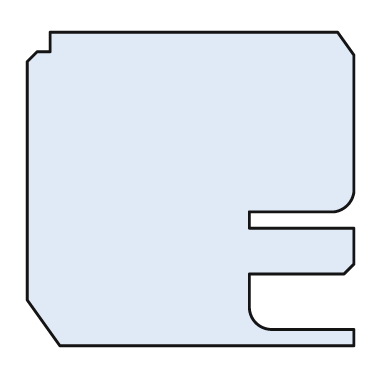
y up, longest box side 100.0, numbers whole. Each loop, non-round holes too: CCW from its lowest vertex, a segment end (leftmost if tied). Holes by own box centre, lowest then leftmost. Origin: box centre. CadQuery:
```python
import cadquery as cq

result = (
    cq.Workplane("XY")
    .moveTo(-40.0, -48.0)
    .lineTo(50.0, -48.0)
    .lineTo(50.0, -43.0)
    .lineTo(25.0, -43.0)
    .threePointArc((20.0, -41.0), (18.0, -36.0))
    .lineTo(18.0, -26.0)
    .lineTo(47.0, -26.0)
    .lineTo(50.0, -23.0)
    .lineTo(50.0, -12.0)
    .lineTo(18.0, -12.0)
    .lineTo(18.0, -7.0)
    .lineTo(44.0, -7.0)
    .threePointArc((48.0, -5.0), (50.0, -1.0))
    .lineTo(50.0, 41.0)
    .lineTo(45.0, 48.0)
    .lineTo(-43.0, 48.0)
    .lineTo(-43.0, 42.0)
    .lineTo(-47.0, 42.0)
    .lineTo(-50.0, 39.0)
    .lineTo(-50.0, -34.0)
    .close()
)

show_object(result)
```